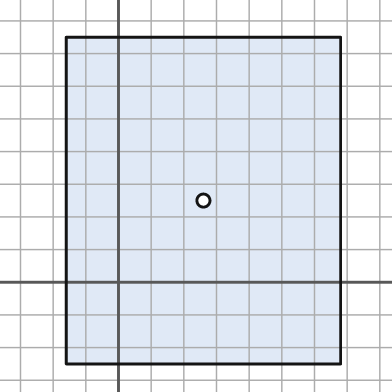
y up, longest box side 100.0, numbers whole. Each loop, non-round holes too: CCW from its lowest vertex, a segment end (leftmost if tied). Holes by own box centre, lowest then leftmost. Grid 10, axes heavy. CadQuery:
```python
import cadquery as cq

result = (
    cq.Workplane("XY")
    .moveTo(-16.0, -25.0)
    .lineTo(68.0, -25.0)
    .lineTo(68.0, 75.0)
    .lineTo(-16.0, 75.0)
    .close()
    .moveTo(26.0, 25.0)
    .circle(2.0)
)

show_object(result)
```